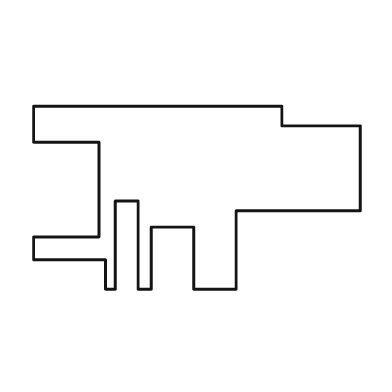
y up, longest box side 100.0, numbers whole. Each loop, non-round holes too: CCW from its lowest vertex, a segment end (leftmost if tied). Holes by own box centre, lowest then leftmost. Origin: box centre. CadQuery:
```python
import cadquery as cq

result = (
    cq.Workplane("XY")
    .moveTo(-28.0, -28.0)
    .lineTo(-25.0, -28.0)
    .lineTo(-25.0, -1.0)
    .lineTo(-18.0, -1.0)
    .lineTo(-18.0, -28.0)
    .lineTo(-14.0, -28.0)
    .lineTo(-14.0, -9.0)
    .lineTo(-1.0, -9.0)
    .lineTo(-1.0, -28.0)
    .lineTo(12.0, -28.0)
    .lineTo(12.0, -4.0)
    .lineTo(50.0, -4.0)
    .lineTo(50.0, 22.0)
    .lineTo(26.0, 22.0)
    .lineTo(26.0, 28.0)
    .lineTo(-50.0, 28.0)
    .lineTo(-50.0, 17.0)
    .lineTo(-30.0, 17.0)
    .lineTo(-30.0, -12.0)
    .lineTo(-50.0, -12.0)
    .lineTo(-50.0, -19.0)
    .lineTo(-28.0, -19.0)
    .close()
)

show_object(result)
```